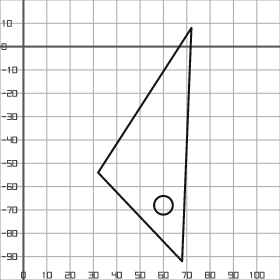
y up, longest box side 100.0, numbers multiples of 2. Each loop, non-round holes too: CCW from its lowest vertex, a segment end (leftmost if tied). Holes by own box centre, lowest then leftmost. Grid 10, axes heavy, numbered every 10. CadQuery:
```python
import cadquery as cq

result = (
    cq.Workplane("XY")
    .moveTo(68.0, -92.0)
    .lineTo(72.0, 8.0)
    .lineTo(32.0, -54.0)
    .close()
    .moveTo(60.0, -68.0)
    .circle(4.0)
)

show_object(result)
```